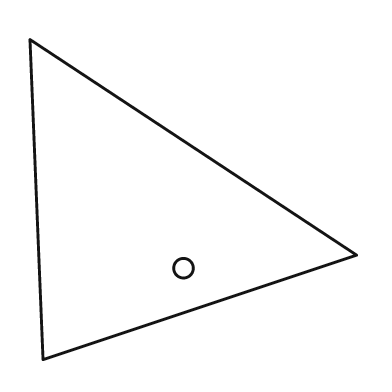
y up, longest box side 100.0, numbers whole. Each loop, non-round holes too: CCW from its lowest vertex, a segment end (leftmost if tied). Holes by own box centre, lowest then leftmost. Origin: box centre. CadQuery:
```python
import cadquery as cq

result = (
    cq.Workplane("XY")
    .moveTo(-46.0, -49.0)
    .lineTo(50.0, -17.0)
    .lineTo(-50.0, 49.0)
    .close()
    .moveTo(-3.0, -21.0)
    .circle(3.0)
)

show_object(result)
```